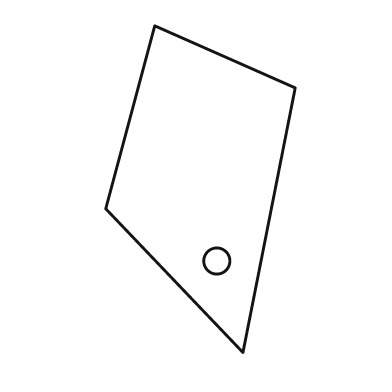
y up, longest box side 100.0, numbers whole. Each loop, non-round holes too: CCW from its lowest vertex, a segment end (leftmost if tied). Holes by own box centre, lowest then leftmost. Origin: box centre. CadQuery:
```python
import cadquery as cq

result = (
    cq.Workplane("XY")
    .moveTo(13.0, -50.0)
    .lineTo(29.0, 31.0)
    .lineTo(-14.0, 50.0)
    .lineTo(-29.0, -6.0)
    .close()
    .moveTo(5.0, -22.0)
    .circle(4.0)
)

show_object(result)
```